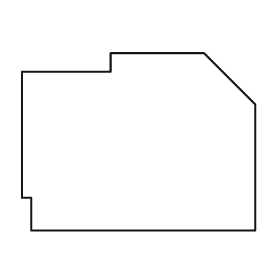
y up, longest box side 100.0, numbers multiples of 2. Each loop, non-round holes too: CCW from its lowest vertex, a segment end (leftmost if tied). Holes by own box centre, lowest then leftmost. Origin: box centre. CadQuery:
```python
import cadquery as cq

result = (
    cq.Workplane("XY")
    .moveTo(-46.0, -38.0)
    .lineTo(50.0, -38.0)
    .lineTo(50.0, 16.0)
    .lineTo(28.0, 38.0)
    .lineTo(-12.0, 38.0)
    .lineTo(-12.0, 30.0)
    .lineTo(-50.0, 30.0)
    .lineTo(-50.0, -24.0)
    .lineTo(-46.0, -24.0)
    .close()
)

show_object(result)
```